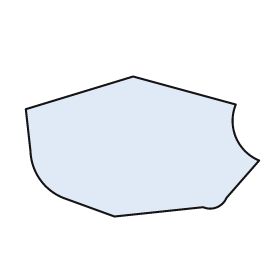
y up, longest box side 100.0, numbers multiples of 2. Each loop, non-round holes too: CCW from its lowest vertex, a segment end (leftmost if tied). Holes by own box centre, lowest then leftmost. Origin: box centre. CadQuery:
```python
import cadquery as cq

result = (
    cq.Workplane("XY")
    .moveTo(-12.0, -30.0)
    .lineTo(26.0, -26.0)
    .threePointArc((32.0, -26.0), (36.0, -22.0))
    .lineTo(50.0, -6.0)
    .threePointArc((40.0, 4.0), (40.0, 18.0))
    .lineTo(-4.0, 30.0)
    .lineTo(-50.0, 16.0)
    .lineTo(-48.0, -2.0)
    .threePointArc((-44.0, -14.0), (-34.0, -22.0))
    .close()
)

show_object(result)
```